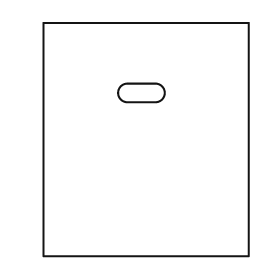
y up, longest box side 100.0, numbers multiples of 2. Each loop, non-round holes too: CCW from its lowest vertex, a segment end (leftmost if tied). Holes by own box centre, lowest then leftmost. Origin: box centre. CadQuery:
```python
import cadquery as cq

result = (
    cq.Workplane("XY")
    .moveTo(-44.0, -50.0)
    .lineTo(44.0, -50.0)
    .lineTo(44.0, 50.0)
    .lineTo(-44.0, 50.0)
    .close()
    .moveTo(-8.0, 16.0)
    .lineTo(4.0, 16.0)
    .threePointArc((8.0, 20.0), (4.0, 24.0))
    .lineTo(-8.0, 24.0)
    .threePointArc((-12.0, 20.0), (-8.0, 16.0))
    .close()
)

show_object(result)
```